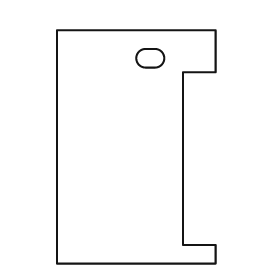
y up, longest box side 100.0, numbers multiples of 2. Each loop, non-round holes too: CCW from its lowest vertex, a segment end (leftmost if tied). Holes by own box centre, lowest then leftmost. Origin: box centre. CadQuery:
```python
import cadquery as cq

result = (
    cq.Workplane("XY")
    .moveTo(-34.0, -50.0)
    .lineTo(34.0, -50.0)
    .lineTo(34.0, -42.0)
    .lineTo(20.0, -42.0)
    .lineTo(20.0, 32.0)
    .lineTo(34.0, 32.0)
    .lineTo(34.0, 50.0)
    .lineTo(-34.0, 50.0)
    .close()
    .moveTo(4.0, 34.0)
    .lineTo(8.0, 34.0)
    .threePointArc((12.0, 38.0), (8.0, 42.0))
    .lineTo(4.0, 42.0)
    .threePointArc((0.0, 38.0), (4.0, 34.0))
    .close()
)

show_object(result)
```